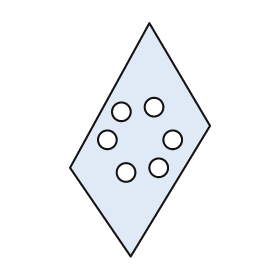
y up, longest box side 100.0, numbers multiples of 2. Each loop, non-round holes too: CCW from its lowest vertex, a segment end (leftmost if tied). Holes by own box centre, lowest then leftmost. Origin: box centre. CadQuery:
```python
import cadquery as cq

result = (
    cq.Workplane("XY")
    .moveTo(-4.0, -50.0)
    .lineTo(30.0, 6.0)
    .lineTo(4.0, 50.0)
    .lineTo(-30.0, -12.0)
    .close()
    .moveTo(-6.0, -14.0)
    .circle(4.0)
    .moveTo(8.0, -12.0)
    .circle(4.0)
    .moveTo(-14.0, 0.0)
    .circle(4.0)
    .moveTo(14.0, 0.0)
    .circle(4.0)
    .moveTo(-8.0, 12.0)
    .circle(4.0)
    .moveTo(6.0, 14.0)
    .circle(4.0)
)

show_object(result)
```